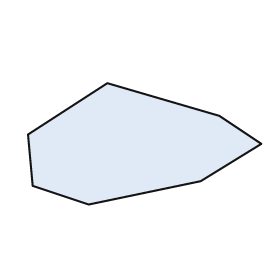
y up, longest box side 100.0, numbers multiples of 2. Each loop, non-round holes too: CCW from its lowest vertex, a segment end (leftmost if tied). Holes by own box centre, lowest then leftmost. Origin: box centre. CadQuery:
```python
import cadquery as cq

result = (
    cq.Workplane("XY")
    .moveTo(-24.0, -26.0)
    .lineTo(24.0, -16.0)
    .lineTo(50.0, 0.0)
    .lineTo(32.0, 12.0)
    .lineTo(-16.0, 26.0)
    .lineTo(-50.0, 4.0)
    .lineTo(-48.0, -18.0)
    .close()
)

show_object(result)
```